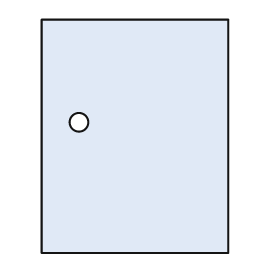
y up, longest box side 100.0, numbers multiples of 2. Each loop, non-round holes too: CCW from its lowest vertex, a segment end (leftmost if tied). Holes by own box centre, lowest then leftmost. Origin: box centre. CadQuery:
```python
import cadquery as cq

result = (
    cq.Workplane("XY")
    .moveTo(-40.0, -50.0)
    .lineTo(40.0, -50.0)
    .lineTo(40.0, 50.0)
    .lineTo(-40.0, 50.0)
    .close()
    .moveTo(-24.0, 6.0)
    .circle(4.0)
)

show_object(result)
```